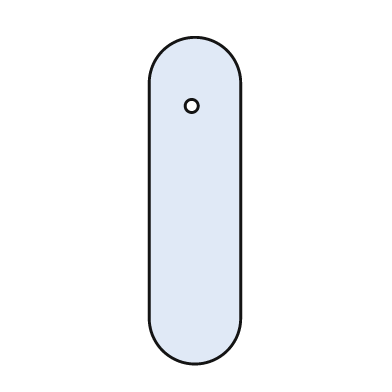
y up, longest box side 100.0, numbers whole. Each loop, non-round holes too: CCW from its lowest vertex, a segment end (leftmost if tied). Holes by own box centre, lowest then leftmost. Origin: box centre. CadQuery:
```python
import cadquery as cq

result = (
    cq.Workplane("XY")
    .moveTo(-14.0, -36.0)
    .threePointArc((0.0, -50.0), (14.0, -36.0))
    .lineTo(14.0, 36.0)
    .threePointArc((0.0, 50.0), (-14.0, 36.0))
    .close()
    .moveTo(-1.0, 29.0)
    .circle(2.0)
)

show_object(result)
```